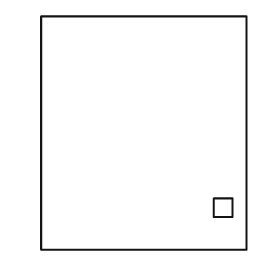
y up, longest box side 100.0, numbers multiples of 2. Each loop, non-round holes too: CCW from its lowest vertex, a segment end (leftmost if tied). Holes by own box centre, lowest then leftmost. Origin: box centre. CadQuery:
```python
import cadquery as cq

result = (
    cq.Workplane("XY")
    .moveTo(-44.0, -50.0)
    .lineTo(44.0, -50.0)
    .lineTo(44.0, 50.0)
    .lineTo(-44.0, 50.0)
    .close()
    .moveTo(30.0, -36.0)
    .lineTo(38.0, -36.0)
    .lineTo(38.0, -28.0)
    .lineTo(30.0, -28.0)
    .close()
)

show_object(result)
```